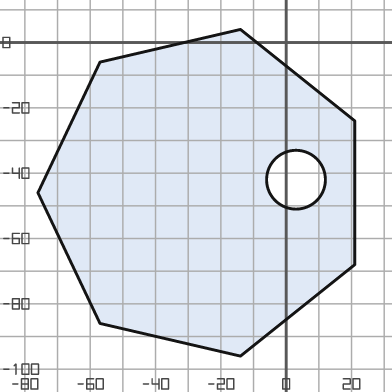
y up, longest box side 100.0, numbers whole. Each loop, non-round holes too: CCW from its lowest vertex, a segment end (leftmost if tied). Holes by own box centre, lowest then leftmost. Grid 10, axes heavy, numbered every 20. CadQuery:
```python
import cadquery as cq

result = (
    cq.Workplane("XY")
    .moveTo(-14.0, -96.0)
    .lineTo(21.0, -68.0)
    .lineTo(21.0, -24.0)
    .lineTo(-14.0, 4.0)
    .lineTo(-57.0, -6.0)
    .lineTo(-76.0, -46.0)
    .lineTo(-57.0, -86.0)
    .close()
    .moveTo(3.0, -42.0)
    .circle(9.0)
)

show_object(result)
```